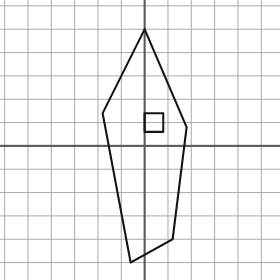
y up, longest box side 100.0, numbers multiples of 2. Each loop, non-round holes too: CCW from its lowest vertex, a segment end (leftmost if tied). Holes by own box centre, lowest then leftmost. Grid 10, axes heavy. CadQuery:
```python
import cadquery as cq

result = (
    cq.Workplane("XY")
    .moveTo(-6.0, -50.0)
    .lineTo(12.0, -40.0)
    .lineTo(18.0, 8.0)
    .lineTo(0.0, 50.0)
    .lineTo(-18.0, 14.0)
    .close()
    .moveTo(0.0, 6.0)
    .lineTo(8.0, 6.0)
    .lineTo(8.0, 14.0)
    .lineTo(0.0, 14.0)
    .close()
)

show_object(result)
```